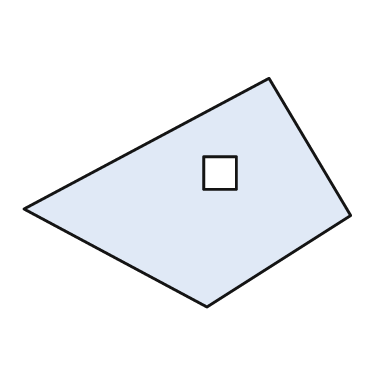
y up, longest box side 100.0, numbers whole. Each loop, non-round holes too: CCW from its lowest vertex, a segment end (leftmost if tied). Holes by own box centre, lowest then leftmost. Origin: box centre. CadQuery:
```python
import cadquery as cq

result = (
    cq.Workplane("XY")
    .moveTo(6.0, -35.0)
    .lineTo(50.0, -7.0)
    .lineTo(25.0, 35.0)
    .lineTo(-50.0, -5.0)
    .close()
    .moveTo(5.0, 1.0)
    .lineTo(15.0, 1.0)
    .lineTo(15.0, 11.0)
    .lineTo(5.0, 11.0)
    .close()
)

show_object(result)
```